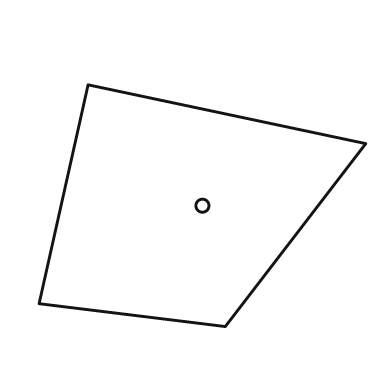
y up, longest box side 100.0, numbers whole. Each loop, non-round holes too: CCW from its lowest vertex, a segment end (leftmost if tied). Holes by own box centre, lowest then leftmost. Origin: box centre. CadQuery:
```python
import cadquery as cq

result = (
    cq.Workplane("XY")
    .moveTo(7.0, -37.0)
    .lineTo(50.0, 19.0)
    .lineTo(-35.0, 37.0)
    .lineTo(-50.0, -30.0)
    .close()
    .moveTo(0.0, 0.0)
    .circle(2.0)
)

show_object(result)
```